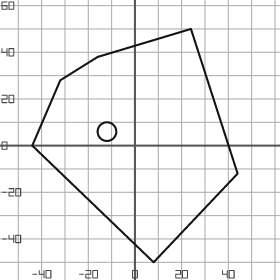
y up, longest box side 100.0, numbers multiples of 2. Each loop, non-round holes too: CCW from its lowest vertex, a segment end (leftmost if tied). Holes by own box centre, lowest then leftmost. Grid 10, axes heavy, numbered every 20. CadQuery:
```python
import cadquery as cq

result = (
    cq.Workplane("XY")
    .moveTo(8.0, -50.0)
    .lineTo(44.0, -12.0)
    .lineTo(24.0, 50.0)
    .lineTo(-16.0, 38.0)
    .lineTo(-32.0, 28.0)
    .lineTo(-44.0, 0.0)
    .close()
    .moveTo(-12.0, 6.0)
    .circle(4.0)
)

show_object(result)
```